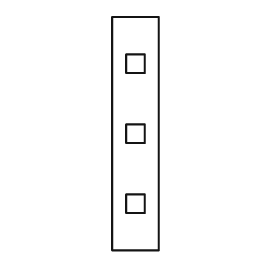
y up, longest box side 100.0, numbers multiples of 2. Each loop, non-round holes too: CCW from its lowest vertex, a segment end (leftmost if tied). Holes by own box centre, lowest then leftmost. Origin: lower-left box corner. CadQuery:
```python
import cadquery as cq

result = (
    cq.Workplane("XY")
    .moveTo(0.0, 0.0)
    .lineTo(20.0, 0.0)
    .lineTo(20.0, 100.0)
    .lineTo(0.0, 100.0)
    .close()
    .moveTo(6.0, 16.0)
    .lineTo(14.0, 16.0)
    .lineTo(14.0, 24.0)
    .lineTo(6.0, 24.0)
    .close()
    .moveTo(6.0, 46.0)
    .lineTo(14.0, 46.0)
    .lineTo(14.0, 54.0)
    .lineTo(6.0, 54.0)
    .close()
    .moveTo(6.0, 76.0)
    .lineTo(14.0, 76.0)
    .lineTo(14.0, 84.0)
    .lineTo(6.0, 84.0)
    .close()
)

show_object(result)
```